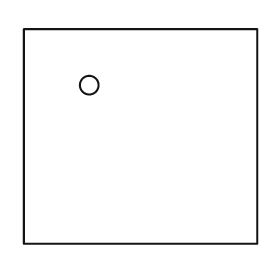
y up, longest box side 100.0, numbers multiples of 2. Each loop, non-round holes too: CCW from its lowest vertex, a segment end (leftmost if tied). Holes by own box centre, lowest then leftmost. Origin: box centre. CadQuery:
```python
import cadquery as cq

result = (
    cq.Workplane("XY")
    .moveTo(-50.0, -46.0)
    .lineTo(50.0, -46.0)
    .lineTo(50.0, 46.0)
    .lineTo(-50.0, 46.0)
    .close()
    .moveTo(-22.0, 22.0)
    .circle(4.0)
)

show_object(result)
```